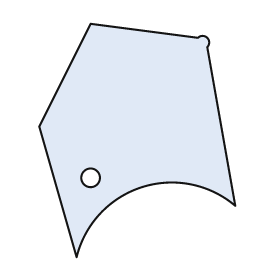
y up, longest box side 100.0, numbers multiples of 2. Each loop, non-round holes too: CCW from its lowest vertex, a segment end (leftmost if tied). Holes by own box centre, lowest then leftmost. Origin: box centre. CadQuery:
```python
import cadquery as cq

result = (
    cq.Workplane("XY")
    .moveTo(-26.0, -50.0)
    .threePointArc((2.0, -20.0), (42.0, -28.0))
    .lineTo(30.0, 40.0)
    .threePointArc((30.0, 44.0), (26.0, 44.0))
    .lineTo(-20.0, 50.0)
    .lineTo(-42.0, 6.0)
    .close()
    .moveTo(-20.0, -16.0)
    .circle(4.0)
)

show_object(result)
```